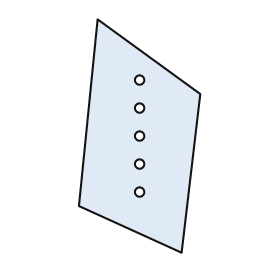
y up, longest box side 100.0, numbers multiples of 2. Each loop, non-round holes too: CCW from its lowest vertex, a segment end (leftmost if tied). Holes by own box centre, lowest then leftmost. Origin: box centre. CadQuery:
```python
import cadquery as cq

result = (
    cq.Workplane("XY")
    .moveTo(18.0, -50.0)
    .lineTo(26.0, 18.0)
    .lineTo(-18.0, 50.0)
    .lineTo(-26.0, -30.0)
    .close()
    .moveTo(0.0, -24.0)
    .circle(2.0)
    .moveTo(0.0, -12.0)
    .circle(2.0)
    .moveTo(0.0, 0.0)
    .circle(2.0)
    .moveTo(0.0, 12.0)
    .circle(2.0)
    .moveTo(0.0, 24.0)
    .circle(2.0)
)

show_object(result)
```